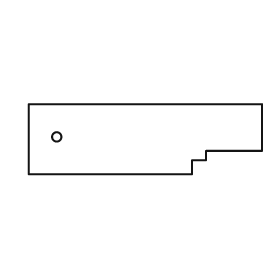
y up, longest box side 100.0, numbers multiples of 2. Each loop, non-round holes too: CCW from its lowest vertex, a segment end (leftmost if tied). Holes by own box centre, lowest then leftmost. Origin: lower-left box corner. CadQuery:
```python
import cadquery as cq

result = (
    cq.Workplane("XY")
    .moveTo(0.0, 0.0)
    .lineTo(70.0, 0.0)
    .lineTo(70.0, 6.0)
    .lineTo(76.0, 6.0)
    .lineTo(76.0, 10.0)
    .lineTo(100.0, 10.0)
    .lineTo(100.0, 30.0)
    .lineTo(0.0, 30.0)
    .close()
    .moveTo(12.0, 16.0)
    .circle(2.0)
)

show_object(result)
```